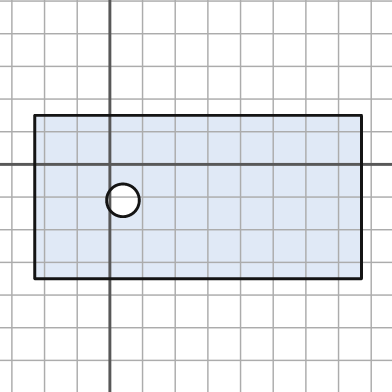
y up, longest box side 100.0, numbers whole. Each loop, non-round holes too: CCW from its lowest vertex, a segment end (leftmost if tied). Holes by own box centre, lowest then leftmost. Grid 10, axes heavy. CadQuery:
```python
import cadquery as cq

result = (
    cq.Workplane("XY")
    .moveTo(-23.0, -35.0)
    .lineTo(77.0, -35.0)
    .lineTo(77.0, 15.0)
    .lineTo(-23.0, 15.0)
    .close()
    .moveTo(4.0, -11.0)
    .circle(5.0)
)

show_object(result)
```